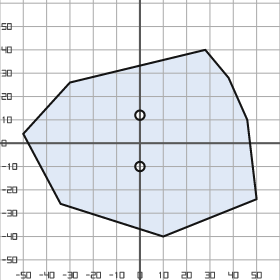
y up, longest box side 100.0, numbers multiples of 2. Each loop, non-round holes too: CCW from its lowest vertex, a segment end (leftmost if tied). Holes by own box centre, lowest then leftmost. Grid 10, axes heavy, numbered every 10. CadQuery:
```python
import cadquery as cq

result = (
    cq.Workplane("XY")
    .moveTo(10.0, -40.0)
    .lineTo(50.0, -24.0)
    .lineTo(46.0, 10.0)
    .lineTo(38.0, 28.0)
    .lineTo(28.0, 40.0)
    .lineTo(-30.0, 26.0)
    .lineTo(-50.0, 4.0)
    .lineTo(-34.0, -26.0)
    .close()
    .moveTo(0.0, -10.0)
    .circle(2.0)
    .moveTo(0.0, 12.0)
    .circle(2.0)
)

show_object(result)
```